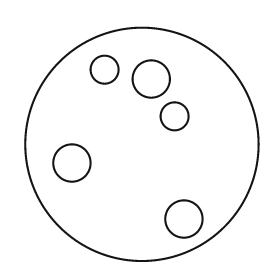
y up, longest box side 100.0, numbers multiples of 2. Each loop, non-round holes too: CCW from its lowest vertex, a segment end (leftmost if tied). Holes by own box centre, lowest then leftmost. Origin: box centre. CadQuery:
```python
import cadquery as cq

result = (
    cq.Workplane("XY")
    .moveTo(0.0, 0.0)
    .circle(50.0)
    .moveTo(18.0, -32.0)
    .circle(8.0)
    .moveTo(-30.0, -8.0)
    .circle(8.0)
    .moveTo(14.0, 12.0)
    .circle(6.0)
    .moveTo(4.0, 28.0)
    .circle(8.0)
    .moveTo(-16.0, 32.0)
    .circle(6.0)
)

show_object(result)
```